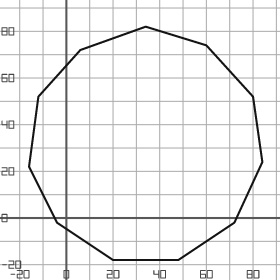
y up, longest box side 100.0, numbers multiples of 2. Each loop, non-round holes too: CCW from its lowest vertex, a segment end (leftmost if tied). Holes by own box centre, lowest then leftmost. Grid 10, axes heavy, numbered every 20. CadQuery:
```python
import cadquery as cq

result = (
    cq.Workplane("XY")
    .moveTo(20.0, -18.0)
    .lineTo(48.0, -18.0)
    .lineTo(72.0, -2.0)
    .lineTo(84.0, 24.0)
    .lineTo(80.0, 52.0)
    .lineTo(60.0, 74.0)
    .lineTo(34.0, 82.0)
    .lineTo(6.0, 72.0)
    .lineTo(-12.0, 52.0)
    .lineTo(-16.0, 22.0)
    .lineTo(-4.0, -2.0)
    .close()
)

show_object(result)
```